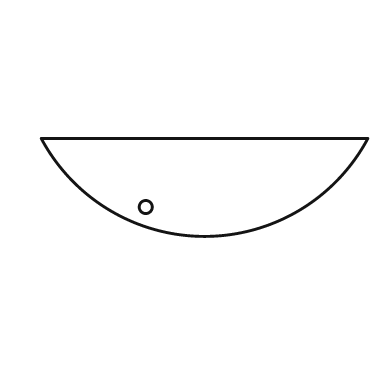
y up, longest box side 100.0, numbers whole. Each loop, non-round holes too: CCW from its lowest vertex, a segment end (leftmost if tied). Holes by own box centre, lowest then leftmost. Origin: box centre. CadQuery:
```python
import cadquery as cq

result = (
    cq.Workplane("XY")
    .moveTo(-50.0, 15.0)
    .threePointArc((0.0, -15.0), (50.0, 15.0))
    .close()
    .moveTo(-18.0, -6.0)
    .circle(2.0)
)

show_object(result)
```